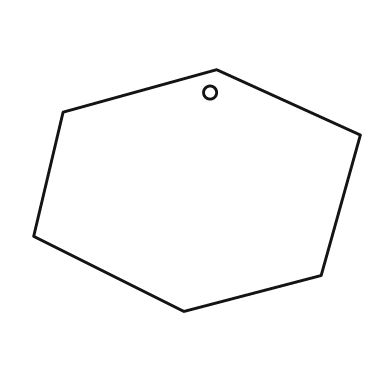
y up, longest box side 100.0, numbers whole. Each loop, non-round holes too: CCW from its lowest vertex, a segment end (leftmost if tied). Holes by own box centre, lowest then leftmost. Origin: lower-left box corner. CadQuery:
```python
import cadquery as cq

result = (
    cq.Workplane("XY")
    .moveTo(46.0, 0.0)
    .lineTo(88.0, 11.0)
    .lineTo(100.0, 54.0)
    .lineTo(56.0, 74.0)
    .lineTo(9.0, 61.0)
    .lineTo(0.0, 23.0)
    .close()
    .moveTo(54.0, 67.0)
    .circle(2.0)
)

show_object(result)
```